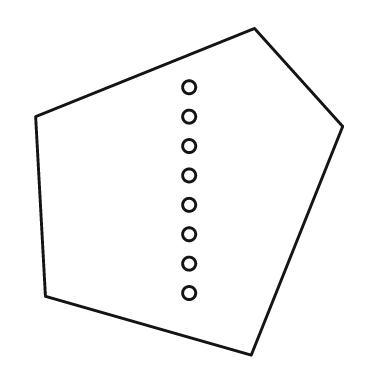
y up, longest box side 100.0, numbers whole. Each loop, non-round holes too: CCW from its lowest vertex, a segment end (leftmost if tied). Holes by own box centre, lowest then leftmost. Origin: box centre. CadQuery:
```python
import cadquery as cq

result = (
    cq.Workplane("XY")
    .moveTo(19.0, -50.0)
    .lineTo(47.0, 20.0)
    .lineTo(20.0, 50.0)
    .lineTo(-47.0, 23.0)
    .lineTo(-44.0, -32.0)
    .close()
    .moveTo(0.0, -31.0)
    .circle(2.0)
    .moveTo(0.0, -22.0)
    .circle(2.0)
    .moveTo(0.0, -13.0)
    .circle(2.0)
    .moveTo(0.0, -4.0)
    .circle(2.0)
    .moveTo(0.0, 5.0)
    .circle(2.0)
    .moveTo(0.0, 14.0)
    .circle(2.0)
    .moveTo(0.0, 23.0)
    .circle(2.0)
    .moveTo(0.0, 32.0)
    .circle(2.0)
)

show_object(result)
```